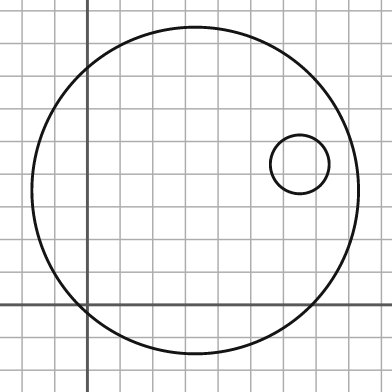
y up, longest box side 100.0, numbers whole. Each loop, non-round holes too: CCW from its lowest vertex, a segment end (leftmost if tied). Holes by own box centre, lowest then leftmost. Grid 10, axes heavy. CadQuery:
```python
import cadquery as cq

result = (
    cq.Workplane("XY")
    .moveTo(33.0, 35.0)
    .circle(50.0)
    .moveTo(65.0, 43.0)
    .circle(9.0)
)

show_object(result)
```